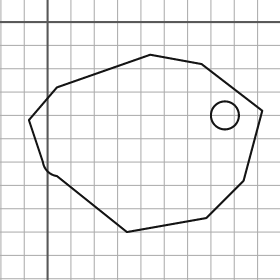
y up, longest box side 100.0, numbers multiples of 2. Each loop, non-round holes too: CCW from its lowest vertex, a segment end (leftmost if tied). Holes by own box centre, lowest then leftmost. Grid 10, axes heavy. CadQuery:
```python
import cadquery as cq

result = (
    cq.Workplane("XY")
    .moveTo(34.0, -90.0)
    .lineTo(68.0, -84.0)
    .lineTo(84.0, -68.0)
    .lineTo(92.0, -38.0)
    .lineTo(66.0, -18.0)
    .lineTo(44.0, -14.0)
    .lineTo(4.0, -28.0)
    .lineTo(-8.0, -42.0)
    .lineTo(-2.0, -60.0)
    .threePointArc((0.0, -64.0), (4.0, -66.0))
    .close()
    .moveTo(76.0, -40.0)
    .circle(6.0)
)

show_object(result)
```